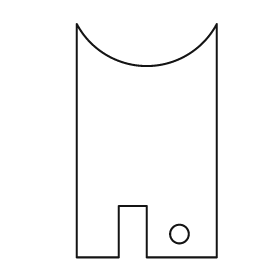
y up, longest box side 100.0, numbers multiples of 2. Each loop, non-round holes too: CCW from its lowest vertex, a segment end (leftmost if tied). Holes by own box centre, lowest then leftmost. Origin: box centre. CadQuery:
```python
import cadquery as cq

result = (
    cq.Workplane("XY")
    .moveTo(-30.0, -50.0)
    .lineTo(-12.0, -50.0)
    .lineTo(-12.0, -28.0)
    .lineTo(0.0, -28.0)
    .lineTo(0.0, -50.0)
    .lineTo(30.0, -50.0)
    .lineTo(30.0, 50.0)
    .threePointArc((0.0, 32.0), (-30.0, 50.0))
    .close()
    .moveTo(14.0, -40.0)
    .circle(4.0)
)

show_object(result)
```